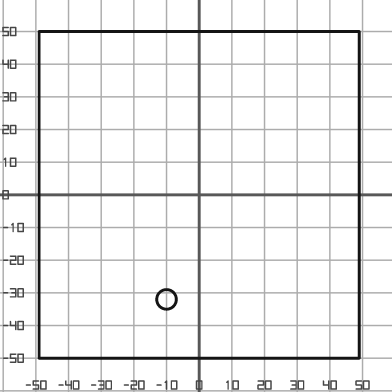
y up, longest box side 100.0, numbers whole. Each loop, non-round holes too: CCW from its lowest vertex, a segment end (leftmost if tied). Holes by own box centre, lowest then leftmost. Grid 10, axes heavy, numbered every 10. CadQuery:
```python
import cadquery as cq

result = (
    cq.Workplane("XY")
    .moveTo(-49.0, -50.0)
    .lineTo(49.0, -50.0)
    .lineTo(49.0, 50.0)
    .lineTo(-49.0, 50.0)
    .close()
    .moveTo(-10.0, -32.0)
    .circle(3.0)
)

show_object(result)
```